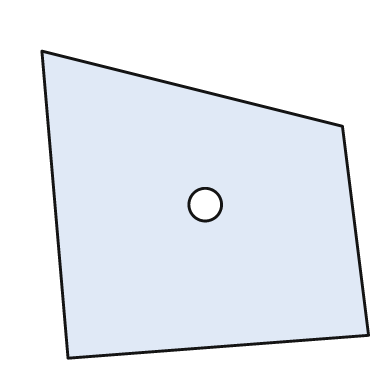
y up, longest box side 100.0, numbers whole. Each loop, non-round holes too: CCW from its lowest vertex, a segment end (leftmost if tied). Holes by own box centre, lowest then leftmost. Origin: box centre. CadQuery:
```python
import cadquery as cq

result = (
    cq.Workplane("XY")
    .moveTo(-42.0, -47.0)
    .lineTo(50.0, -40.0)
    .lineTo(42.0, 24.0)
    .lineTo(-50.0, 47.0)
    .close()
    .moveTo(0.0, 0.0)
    .circle(5.0)
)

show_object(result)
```